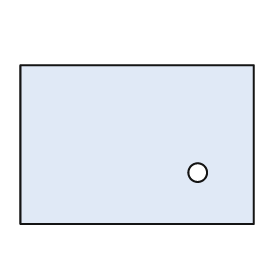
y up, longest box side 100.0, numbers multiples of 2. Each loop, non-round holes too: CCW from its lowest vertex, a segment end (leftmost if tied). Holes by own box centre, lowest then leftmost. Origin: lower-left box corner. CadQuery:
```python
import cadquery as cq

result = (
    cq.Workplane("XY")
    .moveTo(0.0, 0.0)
    .lineTo(100.0, 0.0)
    .lineTo(100.0, 68.0)
    .lineTo(0.0, 68.0)
    .close()
    .moveTo(76.0, 22.0)
    .circle(4.0)
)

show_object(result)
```